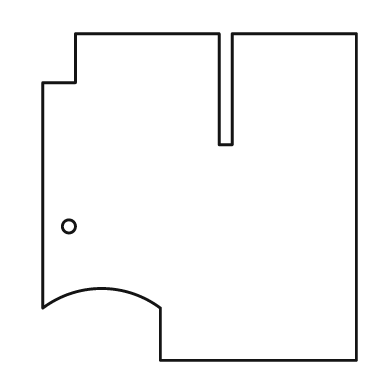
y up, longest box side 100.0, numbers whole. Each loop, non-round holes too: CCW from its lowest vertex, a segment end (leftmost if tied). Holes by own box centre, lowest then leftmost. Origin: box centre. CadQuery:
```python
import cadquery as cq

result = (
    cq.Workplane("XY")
    .moveTo(-12.0, -50.0)
    .lineTo(48.0, -50.0)
    .lineTo(48.0, 50.0)
    .lineTo(10.0, 50.0)
    .lineTo(10.0, 16.0)
    .lineTo(6.0, 16.0)
    .lineTo(6.0, 50.0)
    .lineTo(-38.0, 50.0)
    .lineTo(-38.0, 35.0)
    .lineTo(-48.0, 35.0)
    .lineTo(-48.0, -34.0)
    .threePointArc((-30.0, -28.0), (-12.0, -34.0))
    .close()
    .moveTo(-40.0, -9.0)
    .circle(2.0)
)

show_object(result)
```